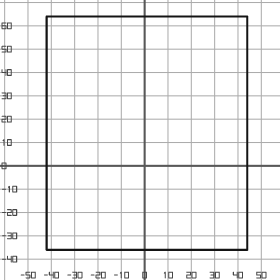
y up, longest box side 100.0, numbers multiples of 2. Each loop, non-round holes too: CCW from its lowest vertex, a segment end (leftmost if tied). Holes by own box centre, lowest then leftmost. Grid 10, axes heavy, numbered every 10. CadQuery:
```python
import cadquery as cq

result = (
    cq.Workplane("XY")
    .moveTo(-42.0, -36.0)
    .lineTo(44.0, -36.0)
    .lineTo(44.0, 64.0)
    .lineTo(-42.0, 64.0)
    .close()
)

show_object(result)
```